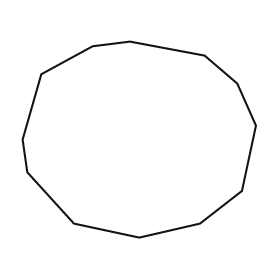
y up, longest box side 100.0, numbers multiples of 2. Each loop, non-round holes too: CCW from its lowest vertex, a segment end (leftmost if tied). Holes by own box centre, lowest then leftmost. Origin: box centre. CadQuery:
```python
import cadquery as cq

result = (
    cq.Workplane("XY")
    .moveTo(0.0, -42.0)
    .lineTo(26.0, -36.0)
    .lineTo(44.0, -22.0)
    .lineTo(50.0, 6.0)
    .lineTo(42.0, 24.0)
    .lineTo(28.0, 36.0)
    .lineTo(-4.0, 42.0)
    .lineTo(-20.0, 40.0)
    .lineTo(-42.0, 28.0)
    .lineTo(-50.0, 0.0)
    .lineTo(-48.0, -14.0)
    .lineTo(-28.0, -36.0)
    .close()
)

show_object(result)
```